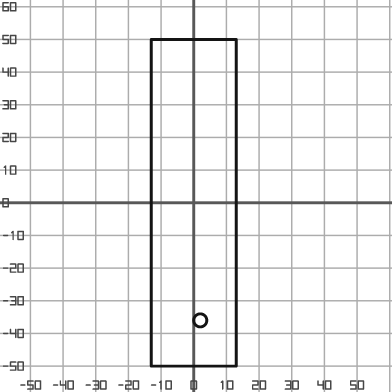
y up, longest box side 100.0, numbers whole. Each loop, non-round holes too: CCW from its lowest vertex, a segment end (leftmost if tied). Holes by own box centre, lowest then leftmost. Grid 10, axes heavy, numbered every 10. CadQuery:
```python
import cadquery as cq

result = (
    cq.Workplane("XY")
    .moveTo(-13.0, -50.0)
    .lineTo(13.0, -50.0)
    .lineTo(13.0, 50.0)
    .lineTo(-13.0, 50.0)
    .close()
    .moveTo(2.0, -36.0)
    .circle(2.0)
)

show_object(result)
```